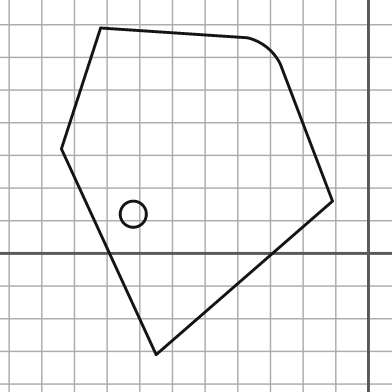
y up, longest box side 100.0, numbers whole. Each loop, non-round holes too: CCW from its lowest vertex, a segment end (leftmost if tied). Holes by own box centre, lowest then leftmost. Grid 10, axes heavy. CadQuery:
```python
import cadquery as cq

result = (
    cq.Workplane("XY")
    .moveTo(-65.0, -31.0)
    .lineTo(-11.0, 16.0)
    .lineTo(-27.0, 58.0)
    .threePointArc((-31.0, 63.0), (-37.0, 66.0))
    .lineTo(-82.0, 69.0)
    .lineTo(-94.0, 32.0)
    .close()
    .moveTo(-72.0, 12.0)
    .circle(4.0)
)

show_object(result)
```